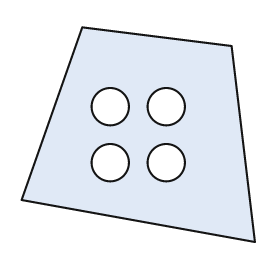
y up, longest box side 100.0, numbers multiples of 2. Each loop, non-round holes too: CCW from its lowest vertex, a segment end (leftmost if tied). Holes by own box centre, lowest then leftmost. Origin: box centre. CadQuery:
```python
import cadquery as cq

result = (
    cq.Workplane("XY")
    .moveTo(50.0, -46.0)
    .lineTo(40.0, 38.0)
    .lineTo(-24.0, 46.0)
    .lineTo(-50.0, -28.0)
    .close()
    .moveTo(-12.0, -12.0)
    .circle(8.0)
    .moveTo(12.0, -12.0)
    .circle(8.0)
    .moveTo(-12.0, 12.0)
    .circle(8.0)
    .moveTo(12.0, 12.0)
    .circle(8.0)
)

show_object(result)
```